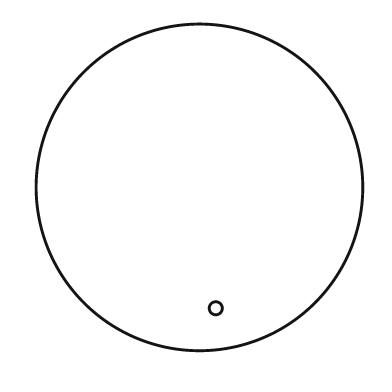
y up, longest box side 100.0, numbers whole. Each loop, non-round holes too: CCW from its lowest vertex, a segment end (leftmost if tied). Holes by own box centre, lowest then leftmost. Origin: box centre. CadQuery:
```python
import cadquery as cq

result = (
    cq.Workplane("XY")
    .moveTo(0.0, 0.0)
    .circle(50.0)
    .moveTo(5.0, -37.0)
    .circle(2.0)
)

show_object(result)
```